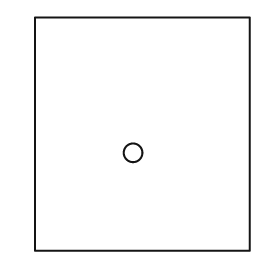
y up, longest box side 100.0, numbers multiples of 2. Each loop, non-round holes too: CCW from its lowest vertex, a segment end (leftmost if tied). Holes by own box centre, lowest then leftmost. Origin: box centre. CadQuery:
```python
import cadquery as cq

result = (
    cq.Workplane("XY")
    .moveTo(-46.0, -50.0)
    .lineTo(46.0, -50.0)
    .lineTo(46.0, 50.0)
    .lineTo(-46.0, 50.0)
    .close()
    .moveTo(-4.0, -8.0)
    .circle(4.0)
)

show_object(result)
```